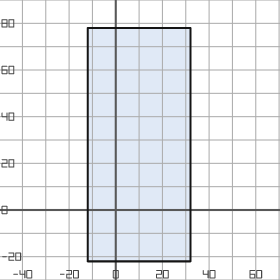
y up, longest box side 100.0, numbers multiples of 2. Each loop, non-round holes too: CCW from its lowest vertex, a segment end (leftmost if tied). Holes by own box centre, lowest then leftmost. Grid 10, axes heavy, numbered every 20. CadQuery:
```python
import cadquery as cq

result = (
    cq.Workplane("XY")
    .moveTo(-12.0, -22.0)
    .lineTo(32.0, -22.0)
    .lineTo(32.0, 78.0)
    .lineTo(-12.0, 78.0)
    .close()
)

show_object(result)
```